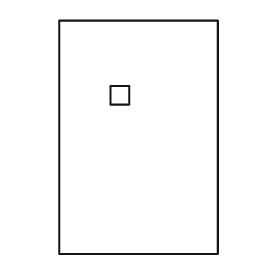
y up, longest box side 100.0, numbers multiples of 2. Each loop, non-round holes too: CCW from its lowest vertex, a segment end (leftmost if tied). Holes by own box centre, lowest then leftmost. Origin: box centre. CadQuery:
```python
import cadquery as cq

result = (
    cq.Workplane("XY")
    .moveTo(-34.0, -50.0)
    .lineTo(34.0, -50.0)
    .lineTo(34.0, 50.0)
    .lineTo(-34.0, 50.0)
    .close()
    .moveTo(-12.0, 14.0)
    .lineTo(-4.0, 14.0)
    .lineTo(-4.0, 22.0)
    .lineTo(-12.0, 22.0)
    .close()
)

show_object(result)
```